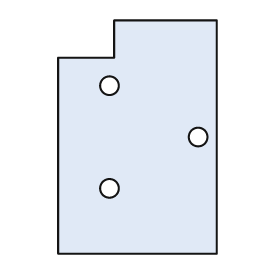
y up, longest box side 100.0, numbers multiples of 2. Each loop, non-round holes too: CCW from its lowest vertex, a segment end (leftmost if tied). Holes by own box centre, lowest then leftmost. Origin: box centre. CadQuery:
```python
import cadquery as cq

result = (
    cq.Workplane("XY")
    .moveTo(-34.0, -50.0)
    .lineTo(34.0, -50.0)
    .lineTo(34.0, 50.0)
    .lineTo(-10.0, 50.0)
    .lineTo(-10.0, 34.0)
    .lineTo(-34.0, 34.0)
    .close()
    .moveTo(-12.0, -22.0)
    .circle(4.0)
    .moveTo(26.0, 0.0)
    .circle(4.0)
    .moveTo(-12.0, 22.0)
    .circle(4.0)
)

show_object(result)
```